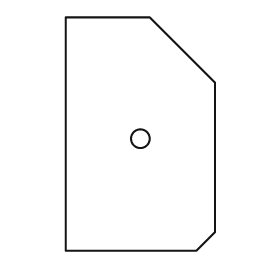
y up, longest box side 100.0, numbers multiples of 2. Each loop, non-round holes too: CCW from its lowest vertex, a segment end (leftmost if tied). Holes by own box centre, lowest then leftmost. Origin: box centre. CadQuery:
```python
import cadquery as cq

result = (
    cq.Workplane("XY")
    .moveTo(-32.0, -50.0)
    .lineTo(24.0, -50.0)
    .lineTo(32.0, -42.0)
    .lineTo(32.0, 22.0)
    .lineTo(4.0, 50.0)
    .lineTo(-32.0, 50.0)
    .close()
    .moveTo(0.0, -2.0)
    .circle(4.0)
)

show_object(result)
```